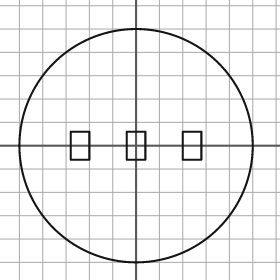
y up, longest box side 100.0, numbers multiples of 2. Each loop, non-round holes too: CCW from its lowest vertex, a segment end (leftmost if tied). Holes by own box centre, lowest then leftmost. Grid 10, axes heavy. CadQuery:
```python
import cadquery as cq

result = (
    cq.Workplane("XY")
    .moveTo(0.0, 0.0)
    .circle(50.0)
    .moveTo(-28.0, -6.0)
    .lineTo(-20.0, -6.0)
    .lineTo(-20.0, 6.0)
    .lineTo(-28.0, 6.0)
    .close()
    .moveTo(-4.0, -6.0)
    .lineTo(4.0, -6.0)
    .lineTo(4.0, 6.0)
    .lineTo(-4.0, 6.0)
    .close()
    .moveTo(20.0, -6.0)
    .lineTo(28.0, -6.0)
    .lineTo(28.0, 6.0)
    .lineTo(20.0, 6.0)
    .close()
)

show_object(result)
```